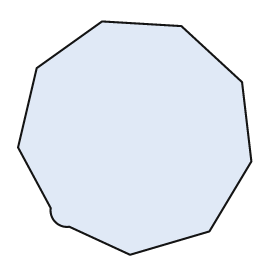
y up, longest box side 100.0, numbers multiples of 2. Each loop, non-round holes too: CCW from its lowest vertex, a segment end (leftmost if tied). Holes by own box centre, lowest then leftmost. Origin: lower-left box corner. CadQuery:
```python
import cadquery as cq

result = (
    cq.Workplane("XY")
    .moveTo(48.0, 0.0)
    .lineTo(82.0, 10.0)
    .lineTo(100.0, 40.0)
    .lineTo(96.0, 74.0)
    .lineTo(70.0, 98.0)
    .lineTo(36.0, 100.0)
    .lineTo(8.0, 80.0)
    .lineTo(0.0, 46.0)
    .lineTo(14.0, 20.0)
    .threePointArc((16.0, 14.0), (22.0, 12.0))
    .close()
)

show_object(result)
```